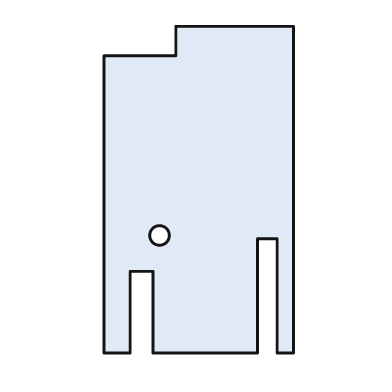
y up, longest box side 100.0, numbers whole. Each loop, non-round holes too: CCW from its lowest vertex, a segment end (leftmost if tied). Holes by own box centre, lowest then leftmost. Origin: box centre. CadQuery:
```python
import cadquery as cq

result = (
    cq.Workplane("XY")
    .moveTo(-29.0, -50.0)
    .lineTo(-21.0, -50.0)
    .lineTo(-21.0, -25.0)
    .lineTo(-14.0, -25.0)
    .lineTo(-14.0, -50.0)
    .lineTo(18.0, -50.0)
    .lineTo(18.0, -15.0)
    .lineTo(24.0, -15.0)
    .lineTo(24.0, -50.0)
    .lineTo(29.0, -50.0)
    .lineTo(29.0, 50.0)
    .lineTo(-7.0, 50.0)
    .lineTo(-7.0, 41.0)
    .lineTo(-29.0, 41.0)
    .close()
    .moveTo(-12.0, -14.0)
    .circle(3.0)
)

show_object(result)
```